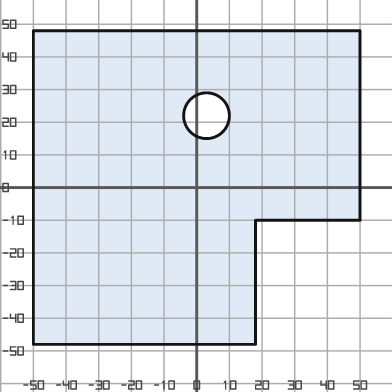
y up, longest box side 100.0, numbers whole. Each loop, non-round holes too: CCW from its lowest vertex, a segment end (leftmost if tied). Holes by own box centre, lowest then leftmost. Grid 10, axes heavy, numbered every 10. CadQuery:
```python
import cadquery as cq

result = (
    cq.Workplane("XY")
    .moveTo(-50.0, -48.0)
    .lineTo(18.0, -48.0)
    .lineTo(18.0, -10.0)
    .lineTo(50.0, -10.0)
    .lineTo(50.0, 48.0)
    .lineTo(-50.0, 48.0)
    .close()
    .moveTo(3.0, 22.0)
    .circle(7.0)
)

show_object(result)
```